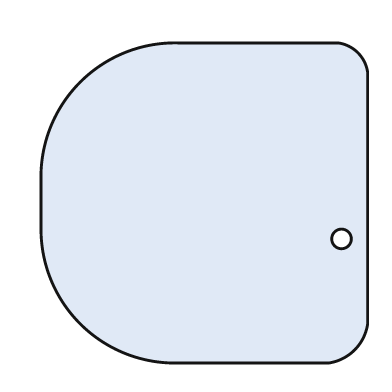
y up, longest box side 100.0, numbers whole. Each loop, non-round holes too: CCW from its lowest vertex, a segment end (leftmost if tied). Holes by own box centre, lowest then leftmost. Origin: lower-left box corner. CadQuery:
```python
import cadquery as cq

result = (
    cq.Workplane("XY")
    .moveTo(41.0, 0.0)
    .lineTo(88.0, 0.0)
    .threePointArc((96.0, 4.0), (100.0, 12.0))
    .lineTo(100.0, 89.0)
    .threePointArc((97.0, 95.0), (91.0, 98.0))
    .lineTo(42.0, 98.0)
    .threePointArc((12.0, 86.0), (0.0, 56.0))
    .lineTo(0.0, 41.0)
    .threePointArc((12.0, 12.0), (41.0, 0.0))
    .close()
    .moveTo(92.0, 38.0)
    .circle(3.0)
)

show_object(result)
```